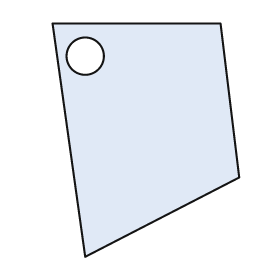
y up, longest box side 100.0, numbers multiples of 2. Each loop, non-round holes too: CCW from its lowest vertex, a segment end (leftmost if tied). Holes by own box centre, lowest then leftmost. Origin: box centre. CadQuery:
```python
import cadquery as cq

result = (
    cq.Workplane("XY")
    .moveTo(-26.0, -50.0)
    .lineTo(40.0, -16.0)
    .lineTo(32.0, 50.0)
    .lineTo(-40.0, 50.0)
    .close()
    .moveTo(-26.0, 36.0)
    .circle(8.0)
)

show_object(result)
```